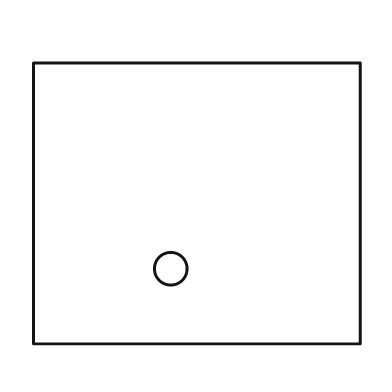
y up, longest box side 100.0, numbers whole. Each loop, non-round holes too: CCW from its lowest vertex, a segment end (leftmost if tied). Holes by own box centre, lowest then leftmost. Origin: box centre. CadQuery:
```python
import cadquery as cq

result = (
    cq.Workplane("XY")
    .moveTo(-50.0, -43.0)
    .lineTo(50.0, -43.0)
    .lineTo(50.0, 43.0)
    .lineTo(-50.0, 43.0)
    .close()
    .moveTo(-8.0, -20.0)
    .circle(5.0)
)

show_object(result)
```